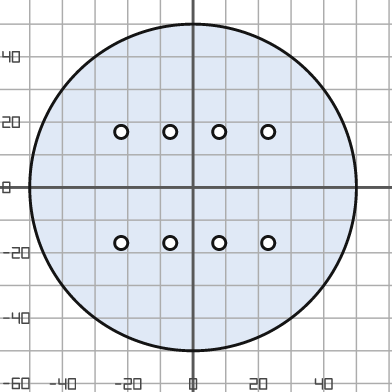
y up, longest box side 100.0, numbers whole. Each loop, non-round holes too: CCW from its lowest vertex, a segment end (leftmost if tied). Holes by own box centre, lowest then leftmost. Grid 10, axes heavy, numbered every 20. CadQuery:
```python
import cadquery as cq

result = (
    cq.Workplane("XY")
    .moveTo(0.0, 0.0)
    .circle(50.0)
    .moveTo(-22.0, -17.0)
    .circle(2.0)
    .moveTo(-7.0, -17.0)
    .circle(2.0)
    .moveTo(8.0, -17.0)
    .circle(2.0)
    .moveTo(23.0, -17.0)
    .circle(2.0)
    .moveTo(-22.0, 17.0)
    .circle(2.0)
    .moveTo(-7.0, 17.0)
    .circle(2.0)
    .moveTo(8.0, 17.0)
    .circle(2.0)
    .moveTo(23.0, 17.0)
    .circle(2.0)
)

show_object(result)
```